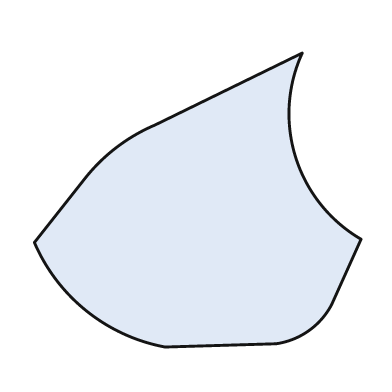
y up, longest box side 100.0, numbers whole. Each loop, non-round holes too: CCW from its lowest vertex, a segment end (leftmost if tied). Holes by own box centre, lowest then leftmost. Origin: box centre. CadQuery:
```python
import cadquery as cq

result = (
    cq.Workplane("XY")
    .moveTo(-10.0, -45.0)
    .lineTo(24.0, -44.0)
    .threePointArc((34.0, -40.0), (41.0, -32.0))
    .lineTo(50.0, -12.0)
    .threePointArc((30.0, 13.0), (32.0, 45.0))
    .lineTo(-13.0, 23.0)
    .threePointArc((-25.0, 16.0), (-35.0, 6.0))
    .lineTo(-50.0, -13.0)
    .threePointArc((-34.0, -34.0), (-10.0, -45.0))
    .close()
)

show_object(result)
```